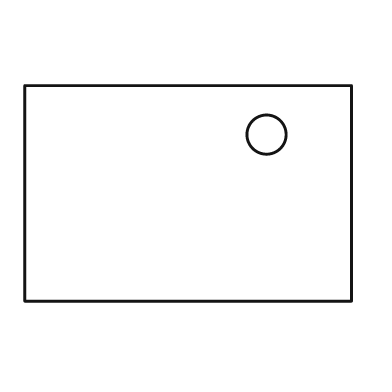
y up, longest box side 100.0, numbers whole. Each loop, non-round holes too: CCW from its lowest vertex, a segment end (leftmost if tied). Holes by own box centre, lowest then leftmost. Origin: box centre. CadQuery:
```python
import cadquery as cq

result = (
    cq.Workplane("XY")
    .moveTo(-50.0, -33.0)
    .lineTo(50.0, -33.0)
    .lineTo(50.0, 33.0)
    .lineTo(-50.0, 33.0)
    .close()
    .moveTo(24.0, 18.0)
    .circle(6.0)
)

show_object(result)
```